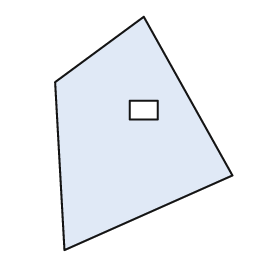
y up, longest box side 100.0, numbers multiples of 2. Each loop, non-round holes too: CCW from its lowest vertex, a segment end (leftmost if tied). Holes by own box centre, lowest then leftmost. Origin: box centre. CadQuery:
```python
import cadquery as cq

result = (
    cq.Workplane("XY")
    .moveTo(-34.0, -50.0)
    .lineTo(38.0, -18.0)
    .lineTo(0.0, 50.0)
    .lineTo(-38.0, 22.0)
    .close()
    .moveTo(-6.0, 6.0)
    .lineTo(6.0, 6.0)
    .lineTo(6.0, 14.0)
    .lineTo(-6.0, 14.0)
    .close()
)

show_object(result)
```